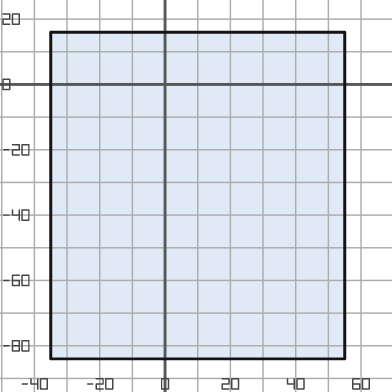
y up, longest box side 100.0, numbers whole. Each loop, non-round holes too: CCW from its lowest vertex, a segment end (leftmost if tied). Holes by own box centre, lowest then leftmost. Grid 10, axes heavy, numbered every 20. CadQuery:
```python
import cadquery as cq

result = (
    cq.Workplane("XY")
    .moveTo(-35.0, -84.0)
    .lineTo(55.0, -84.0)
    .lineTo(55.0, 16.0)
    .lineTo(-35.0, 16.0)
    .close()
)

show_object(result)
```